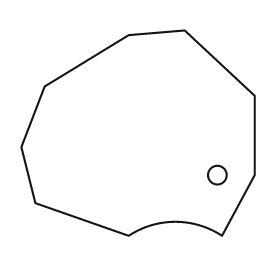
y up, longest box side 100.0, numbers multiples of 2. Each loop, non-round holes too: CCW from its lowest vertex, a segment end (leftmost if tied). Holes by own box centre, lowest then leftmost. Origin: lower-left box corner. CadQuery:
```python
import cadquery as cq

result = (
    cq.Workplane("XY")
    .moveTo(46.0, 0.0)
    .threePointArc((66.0, 6.0), (86.0, 0.0))
    .lineTo(100.0, 26.0)
    .lineTo(100.0, 60.0)
    .lineTo(70.0, 88.0)
    .lineTo(46.0, 86.0)
    .lineTo(10.0, 64.0)
    .lineTo(0.0, 38.0)
    .lineTo(6.0, 14.0)
    .close()
    .moveTo(84.0, 26.0)
    .circle(4.0)
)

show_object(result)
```